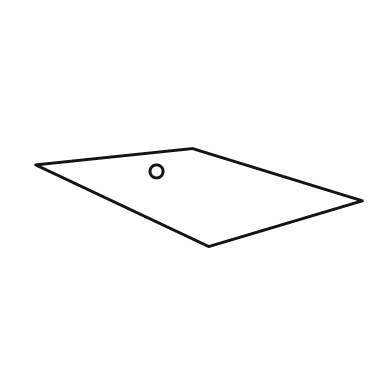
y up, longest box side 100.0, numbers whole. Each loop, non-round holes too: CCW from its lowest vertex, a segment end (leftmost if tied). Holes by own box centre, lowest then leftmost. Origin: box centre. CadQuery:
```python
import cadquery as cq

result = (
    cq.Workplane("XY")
    .moveTo(3.0, -15.0)
    .lineTo(50.0, -1.0)
    .lineTo(-2.0, 15.0)
    .lineTo(-50.0, 10.0)
    .close()
    .moveTo(-13.0, 8.0)
    .circle(2.0)
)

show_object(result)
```